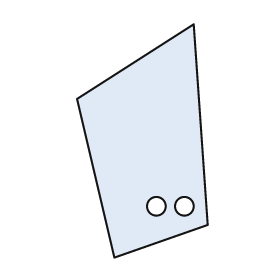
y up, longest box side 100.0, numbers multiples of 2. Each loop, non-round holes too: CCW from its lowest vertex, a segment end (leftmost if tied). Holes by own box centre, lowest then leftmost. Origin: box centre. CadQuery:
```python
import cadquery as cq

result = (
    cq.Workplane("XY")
    .moveTo(-12.0, -50.0)
    .lineTo(28.0, -36.0)
    .lineTo(22.0, 50.0)
    .lineTo(-28.0, 18.0)
    .close()
    .moveTo(6.0, -28.0)
    .circle(4.0)
    .moveTo(18.0, -28.0)
    .circle(4.0)
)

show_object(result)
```